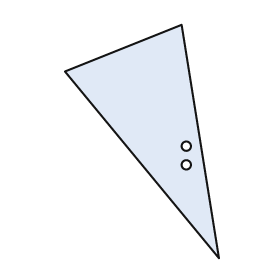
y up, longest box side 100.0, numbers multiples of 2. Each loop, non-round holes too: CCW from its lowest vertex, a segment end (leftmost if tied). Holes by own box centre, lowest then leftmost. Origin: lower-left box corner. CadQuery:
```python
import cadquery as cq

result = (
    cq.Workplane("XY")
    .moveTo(66.0, 0.0)
    .lineTo(50.0, 100.0)
    .lineTo(0.0, 80.0)
    .close()
    .moveTo(52.0, 40.0)
    .circle(2.0)
    .moveTo(52.0, 48.0)
    .circle(2.0)
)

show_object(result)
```